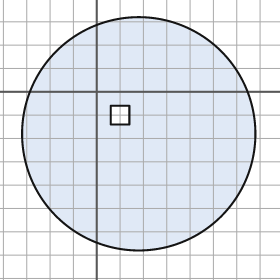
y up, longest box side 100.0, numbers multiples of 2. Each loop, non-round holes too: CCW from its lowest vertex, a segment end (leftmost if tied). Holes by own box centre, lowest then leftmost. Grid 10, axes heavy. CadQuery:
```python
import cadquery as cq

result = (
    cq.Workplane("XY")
    .moveTo(18.0, -18.0)
    .circle(50.0)
    .moveTo(6.0, -14.0)
    .lineTo(14.0, -14.0)
    .lineTo(14.0, -6.0)
    .lineTo(6.0, -6.0)
    .close()
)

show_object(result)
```